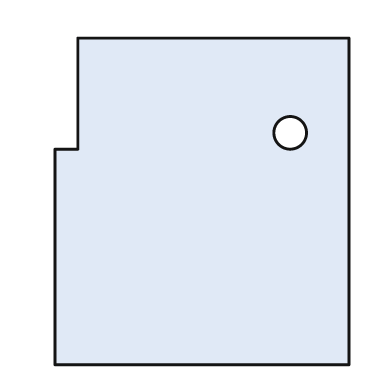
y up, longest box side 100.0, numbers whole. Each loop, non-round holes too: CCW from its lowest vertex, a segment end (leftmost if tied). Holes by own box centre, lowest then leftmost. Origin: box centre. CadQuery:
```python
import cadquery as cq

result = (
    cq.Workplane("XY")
    .moveTo(-45.0, -50.0)
    .lineTo(45.0, -50.0)
    .lineTo(45.0, 50.0)
    .lineTo(-38.0, 50.0)
    .lineTo(-38.0, 16.0)
    .lineTo(-45.0, 16.0)
    .close()
    .moveTo(27.0, 21.0)
    .circle(5.0)
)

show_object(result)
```